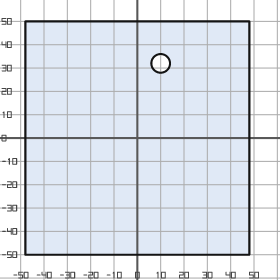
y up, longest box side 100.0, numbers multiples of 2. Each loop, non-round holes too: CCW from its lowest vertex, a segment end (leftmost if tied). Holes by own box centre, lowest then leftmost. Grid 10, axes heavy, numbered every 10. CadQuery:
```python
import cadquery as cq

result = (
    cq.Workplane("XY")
    .moveTo(-48.0, -50.0)
    .lineTo(48.0, -50.0)
    .lineTo(48.0, 50.0)
    .lineTo(-48.0, 50.0)
    .close()
    .moveTo(10.0, 32.0)
    .circle(4.0)
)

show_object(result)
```